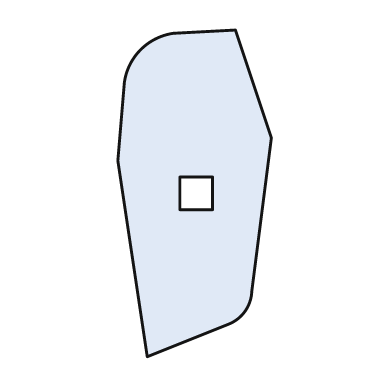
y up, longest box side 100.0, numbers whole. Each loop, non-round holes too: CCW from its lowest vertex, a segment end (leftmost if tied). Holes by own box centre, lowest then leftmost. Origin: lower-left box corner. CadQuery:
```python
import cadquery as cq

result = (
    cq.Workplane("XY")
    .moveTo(9.0, 0.0)
    .lineTo(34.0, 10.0)
    .threePointArc((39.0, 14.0), (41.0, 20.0))
    .lineTo(47.0, 67.0)
    .lineTo(36.0, 100.0)
    .lineTo(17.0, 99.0)
    .threePointArc((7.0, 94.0), (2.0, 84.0))
    .lineTo(0.0, 60.0)
    .close()
    .moveTo(19.0, 45.0)
    .lineTo(29.0, 45.0)
    .lineTo(29.0, 55.0)
    .lineTo(19.0, 55.0)
    .close()
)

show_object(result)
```